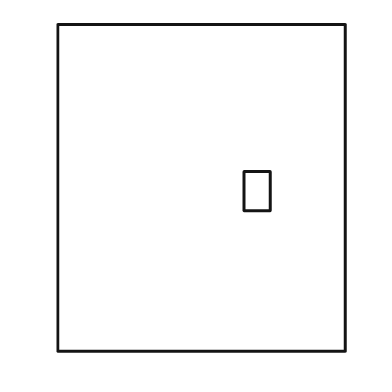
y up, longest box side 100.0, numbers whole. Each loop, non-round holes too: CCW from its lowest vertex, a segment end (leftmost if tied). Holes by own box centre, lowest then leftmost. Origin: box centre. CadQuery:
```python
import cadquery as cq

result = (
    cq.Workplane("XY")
    .moveTo(-44.0, -50.0)
    .lineTo(44.0, -50.0)
    .lineTo(44.0, 50.0)
    .lineTo(-44.0, 50.0)
    .close()
    .moveTo(13.0, -7.0)
    .lineTo(21.0, -7.0)
    .lineTo(21.0, 5.0)
    .lineTo(13.0, 5.0)
    .close()
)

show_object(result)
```